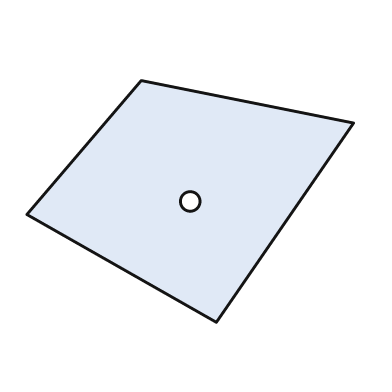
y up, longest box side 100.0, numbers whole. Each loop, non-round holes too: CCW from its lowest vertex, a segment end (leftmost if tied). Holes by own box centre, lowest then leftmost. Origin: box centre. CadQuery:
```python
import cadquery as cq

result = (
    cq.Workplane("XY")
    .moveTo(8.0, -37.0)
    .lineTo(50.0, 24.0)
    .lineTo(-15.0, 37.0)
    .lineTo(-50.0, -4.0)
    .close()
    .moveTo(0.0, 0.0)
    .circle(3.0)
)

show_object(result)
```